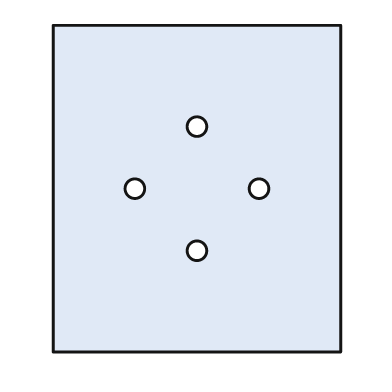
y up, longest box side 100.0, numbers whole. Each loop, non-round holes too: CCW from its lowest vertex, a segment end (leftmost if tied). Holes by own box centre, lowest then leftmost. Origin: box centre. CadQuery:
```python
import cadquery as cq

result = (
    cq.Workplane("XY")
    .moveTo(-44.0, -50.0)
    .lineTo(44.0, -50.0)
    .lineTo(44.0, 50.0)
    .lineTo(-44.0, 50.0)
    .close()
    .moveTo(0.0, -19.0)
    .circle(3.0)
    .moveTo(-19.0, 0.0)
    .circle(3.0)
    .moveTo(19.0, 0.0)
    .circle(3.0)
    .moveTo(0.0, 19.0)
    .circle(3.0)
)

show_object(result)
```